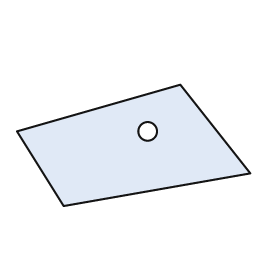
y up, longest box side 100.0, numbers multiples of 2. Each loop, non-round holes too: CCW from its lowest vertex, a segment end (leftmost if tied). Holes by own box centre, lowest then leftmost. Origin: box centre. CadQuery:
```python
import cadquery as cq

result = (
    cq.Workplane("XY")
    .moveTo(-30.0, -26.0)
    .lineTo(50.0, -12.0)
    .lineTo(20.0, 26.0)
    .lineTo(-50.0, 6.0)
    .close()
    .moveTo(6.0, 6.0)
    .circle(4.0)
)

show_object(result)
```